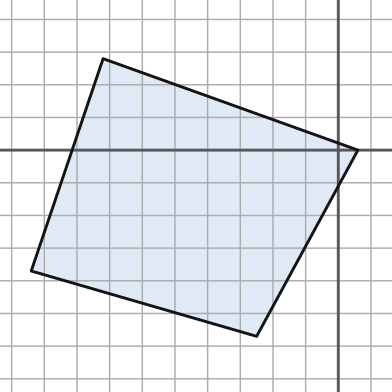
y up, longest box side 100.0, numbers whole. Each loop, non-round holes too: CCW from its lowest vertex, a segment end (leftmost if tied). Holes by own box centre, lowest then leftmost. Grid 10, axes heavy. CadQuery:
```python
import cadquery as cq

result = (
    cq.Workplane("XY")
    .moveTo(-25.0, -57.0)
    .lineTo(6.0, 0.0)
    .lineTo(-72.0, 28.0)
    .lineTo(-94.0, -37.0)
    .close()
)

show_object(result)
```